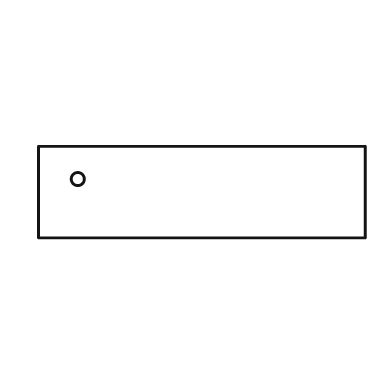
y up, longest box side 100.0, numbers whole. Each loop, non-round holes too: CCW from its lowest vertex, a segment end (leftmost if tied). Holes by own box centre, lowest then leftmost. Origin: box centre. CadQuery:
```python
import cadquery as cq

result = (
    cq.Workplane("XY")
    .moveTo(-50.0, -14.0)
    .lineTo(50.0, -14.0)
    .lineTo(50.0, 14.0)
    .lineTo(-50.0, 14.0)
    .close()
    .moveTo(-38.0, 4.0)
    .circle(2.0)
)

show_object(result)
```